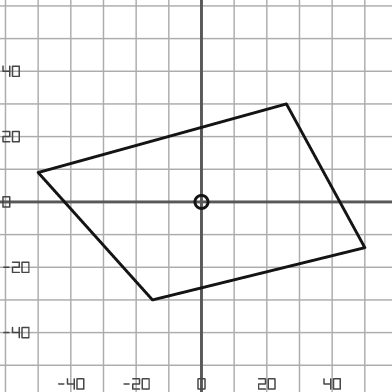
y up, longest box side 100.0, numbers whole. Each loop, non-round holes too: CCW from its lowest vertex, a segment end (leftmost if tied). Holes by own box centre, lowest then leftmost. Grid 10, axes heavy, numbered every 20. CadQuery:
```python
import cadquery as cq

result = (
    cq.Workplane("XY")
    .moveTo(-15.0, -30.0)
    .lineTo(50.0, -14.0)
    .lineTo(26.0, 30.0)
    .lineTo(-50.0, 9.0)
    .close()
    .moveTo(0.0, 0.0)
    .circle(2.0)
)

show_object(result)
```